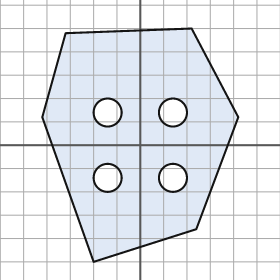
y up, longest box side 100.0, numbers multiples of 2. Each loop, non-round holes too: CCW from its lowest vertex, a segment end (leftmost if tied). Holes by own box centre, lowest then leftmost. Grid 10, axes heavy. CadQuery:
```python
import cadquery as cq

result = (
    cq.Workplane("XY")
    .moveTo(-20.0, -50.0)
    .lineTo(24.0, -36.0)
    .lineTo(42.0, 12.0)
    .lineTo(22.0, 50.0)
    .lineTo(-32.0, 48.0)
    .lineTo(-42.0, 12.0)
    .close()
    .moveTo(-14.0, -14.0)
    .circle(6.0)
    .moveTo(14.0, -14.0)
    .circle(6.0)
    .moveTo(-14.0, 14.0)
    .circle(6.0)
    .moveTo(14.0, 14.0)
    .circle(6.0)
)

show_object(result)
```